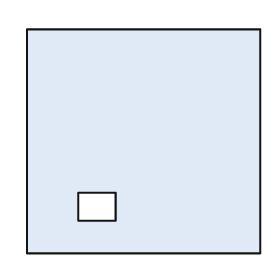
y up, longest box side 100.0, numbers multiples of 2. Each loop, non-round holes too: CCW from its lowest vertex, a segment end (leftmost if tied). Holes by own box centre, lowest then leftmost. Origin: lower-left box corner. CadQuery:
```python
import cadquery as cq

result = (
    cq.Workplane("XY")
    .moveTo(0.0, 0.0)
    .lineTo(100.0, 0.0)
    .lineTo(100.0, 96.0)
    .lineTo(0.0, 96.0)
    .close()
    .moveTo(22.0, 14.0)
    .lineTo(38.0, 14.0)
    .lineTo(38.0, 26.0)
    .lineTo(22.0, 26.0)
    .close()
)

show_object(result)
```